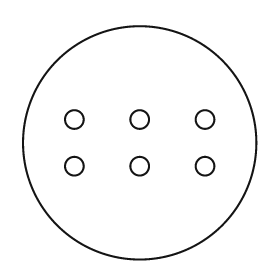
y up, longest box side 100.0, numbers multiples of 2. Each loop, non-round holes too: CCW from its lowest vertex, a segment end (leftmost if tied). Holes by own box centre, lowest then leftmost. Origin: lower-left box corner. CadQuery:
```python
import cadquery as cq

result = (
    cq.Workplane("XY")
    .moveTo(50.0, 50.0)
    .circle(50.0)
    .moveTo(22.0, 40.0)
    .circle(4.0)
    .moveTo(50.0, 40.0)
    .circle(4.0)
    .moveTo(78.0, 40.0)
    .circle(4.0)
    .moveTo(22.0, 60.0)
    .circle(4.0)
    .moveTo(50.0, 60.0)
    .circle(4.0)
    .moveTo(78.0, 60.0)
    .circle(4.0)
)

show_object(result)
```